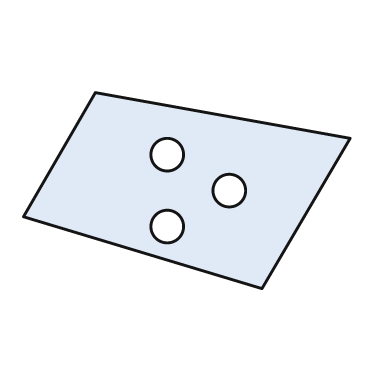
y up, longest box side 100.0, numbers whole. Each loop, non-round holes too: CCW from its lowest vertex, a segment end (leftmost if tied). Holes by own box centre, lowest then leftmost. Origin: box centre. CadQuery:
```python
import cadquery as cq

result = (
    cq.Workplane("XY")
    .moveTo(23.0, -30.0)
    .lineTo(50.0, 16.0)
    .lineTo(-28.0, 30.0)
    .lineTo(-50.0, -8.0)
    .close()
    .moveTo(-6.0, -11.0)
    .circle(5.0)
    .moveTo(13.0, 0.0)
    .circle(5.0)
    .moveTo(-6.0, 11.0)
    .circle(5.0)
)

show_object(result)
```